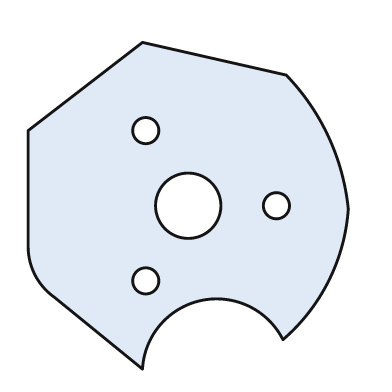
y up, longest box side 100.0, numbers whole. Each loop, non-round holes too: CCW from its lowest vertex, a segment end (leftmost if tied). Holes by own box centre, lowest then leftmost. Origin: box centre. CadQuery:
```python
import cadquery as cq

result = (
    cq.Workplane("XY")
    .moveTo(-14.0, -50.0)
    .threePointArc((4.0, -29.0), (29.0, -41.0))
    .threePointArc((43.0, -23.0), (49.0, -1.0))
    .threePointArc((43.0, 21.0), (30.0, 40.0))
    .lineTo(-14.0, 50.0)
    .lineTo(-49.0, 23.0)
    .lineTo(-49.0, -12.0)
    .threePointArc((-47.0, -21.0), (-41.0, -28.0))
    .close()
    .moveTo(-13.0, -23.0)
    .circle(4.0)
    .moveTo(0.0, 0.0)
    .circle(10.0)
    .moveTo(27.0, 0.0)
    .circle(4.0)
    .moveTo(-13.0, 23.0)
    .circle(4.0)
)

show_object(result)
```